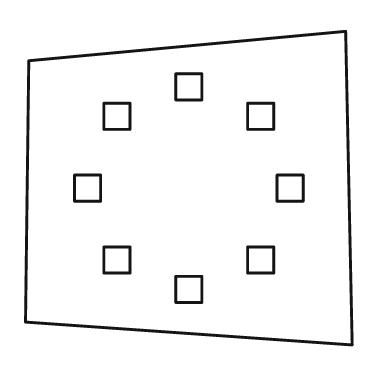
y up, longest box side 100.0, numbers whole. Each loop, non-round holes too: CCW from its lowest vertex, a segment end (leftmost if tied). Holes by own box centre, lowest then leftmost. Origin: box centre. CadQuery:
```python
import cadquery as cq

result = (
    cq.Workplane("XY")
    .moveTo(50.0, -48.0)
    .lineTo(48.0, 48.0)
    .lineTo(-49.0, 39.0)
    .lineTo(-50.0, -41.0)
    .close()
    .moveTo(-4.0, -35.0)
    .lineTo(4.0, -35.0)
    .lineTo(4.0, -27.0)
    .lineTo(-4.0, -27.0)
    .close()
    .moveTo(-26.0, -26.0)
    .lineTo(-18.0, -26.0)
    .lineTo(-18.0, -18.0)
    .lineTo(-26.0, -18.0)
    .close()
    .moveTo(18.0, -26.0)
    .lineTo(26.0, -26.0)
    .lineTo(26.0, -18.0)
    .lineTo(18.0, -18.0)
    .close()
    .moveTo(-35.0, -4.0)
    .lineTo(-27.0, -4.0)
    .lineTo(-27.0, 4.0)
    .lineTo(-35.0, 4.0)
    .close()
    .moveTo(27.0, -4.0)
    .lineTo(35.0, -4.0)
    .lineTo(35.0, 4.0)
    .lineTo(27.0, 4.0)
    .close()
    .moveTo(-26.0, 18.0)
    .lineTo(-18.0, 18.0)
    .lineTo(-18.0, 26.0)
    .lineTo(-26.0, 26.0)
    .close()
    .moveTo(18.0, 18.0)
    .lineTo(26.0, 18.0)
    .lineTo(26.0, 26.0)
    .lineTo(18.0, 26.0)
    .close()
    .moveTo(-4.0, 27.0)
    .lineTo(4.0, 27.0)
    .lineTo(4.0, 35.0)
    .lineTo(-4.0, 35.0)
    .close()
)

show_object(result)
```